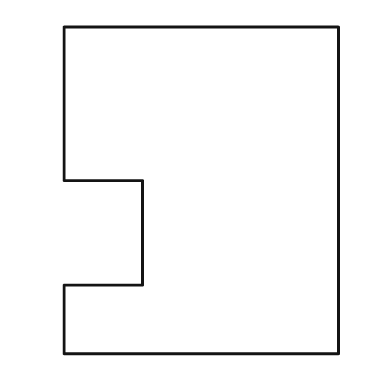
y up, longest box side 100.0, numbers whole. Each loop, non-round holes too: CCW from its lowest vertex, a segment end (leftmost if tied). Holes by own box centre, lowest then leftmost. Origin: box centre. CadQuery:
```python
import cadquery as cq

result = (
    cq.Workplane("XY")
    .moveTo(-42.0, -50.0)
    .lineTo(42.0, -50.0)
    .lineTo(42.0, 50.0)
    .lineTo(-42.0, 50.0)
    .lineTo(-42.0, 3.0)
    .lineTo(-18.0, 3.0)
    .lineTo(-18.0, -29.0)
    .lineTo(-42.0, -29.0)
    .close()
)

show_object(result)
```